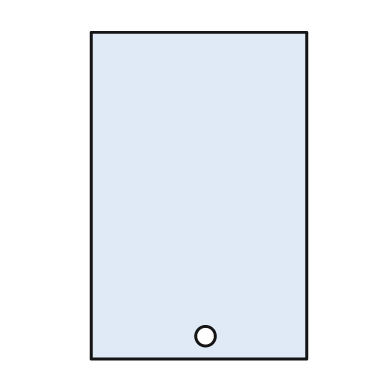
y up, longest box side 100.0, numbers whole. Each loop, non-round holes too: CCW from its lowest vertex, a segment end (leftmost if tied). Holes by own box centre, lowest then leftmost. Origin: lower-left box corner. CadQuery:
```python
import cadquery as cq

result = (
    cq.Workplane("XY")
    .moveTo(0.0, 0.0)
    .lineTo(66.0, 0.0)
    .lineTo(66.0, 100.0)
    .lineTo(0.0, 100.0)
    .close()
    .moveTo(35.0, 7.0)
    .circle(3.0)
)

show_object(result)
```